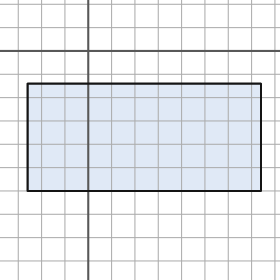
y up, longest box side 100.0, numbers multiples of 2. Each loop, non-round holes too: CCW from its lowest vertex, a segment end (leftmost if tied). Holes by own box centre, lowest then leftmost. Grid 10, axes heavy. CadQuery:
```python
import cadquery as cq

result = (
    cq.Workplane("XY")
    .moveTo(-26.0, -60.0)
    .lineTo(74.0, -60.0)
    .lineTo(74.0, -14.0)
    .lineTo(-26.0, -14.0)
    .close()
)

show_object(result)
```